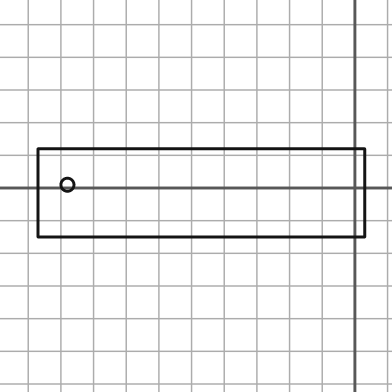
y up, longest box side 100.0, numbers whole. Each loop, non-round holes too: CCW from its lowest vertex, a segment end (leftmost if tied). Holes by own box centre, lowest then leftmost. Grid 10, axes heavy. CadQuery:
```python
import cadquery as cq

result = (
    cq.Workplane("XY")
    .moveTo(-97.0, -15.0)
    .lineTo(3.0, -15.0)
    .lineTo(3.0, 12.0)
    .lineTo(-97.0, 12.0)
    .close()
    .moveTo(-88.0, 1.0)
    .circle(2.0)
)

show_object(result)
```